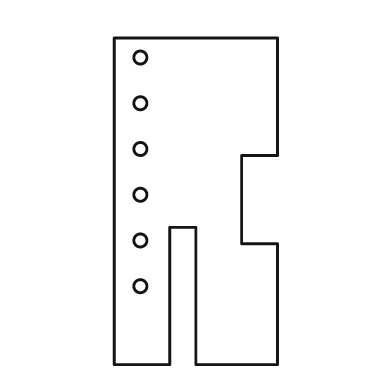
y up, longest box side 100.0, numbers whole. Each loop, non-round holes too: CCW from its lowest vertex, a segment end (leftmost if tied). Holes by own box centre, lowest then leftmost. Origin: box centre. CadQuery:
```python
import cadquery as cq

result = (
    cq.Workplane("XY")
    .moveTo(-25.0, -50.0)
    .lineTo(-8.0, -50.0)
    .lineTo(-8.0, -8.0)
    .lineTo(0.0, -8.0)
    .lineTo(0.0, -50.0)
    .lineTo(25.0, -50.0)
    .lineTo(25.0, -13.0)
    .lineTo(14.0, -13.0)
    .lineTo(14.0, 14.0)
    .lineTo(25.0, 14.0)
    .lineTo(25.0, 50.0)
    .lineTo(-25.0, 50.0)
    .close()
    .moveTo(-17.0, -26.0)
    .circle(2.0)
    .moveTo(-17.0, -12.0)
    .circle(2.0)
    .moveTo(-17.0, 2.0)
    .circle(2.0)
    .moveTo(-17.0, 16.0)
    .circle(2.0)
    .moveTo(-17.0, 30.0)
    .circle(2.0)
    .moveTo(-17.0, 44.0)
    .circle(2.0)
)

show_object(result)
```